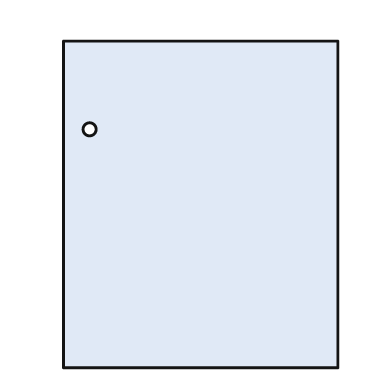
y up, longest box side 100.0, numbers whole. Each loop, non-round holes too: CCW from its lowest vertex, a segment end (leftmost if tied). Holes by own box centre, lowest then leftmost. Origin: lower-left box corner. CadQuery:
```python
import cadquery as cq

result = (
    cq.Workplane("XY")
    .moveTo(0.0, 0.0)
    .lineTo(84.0, 0.0)
    .lineTo(84.0, 100.0)
    .lineTo(0.0, 100.0)
    .close()
    .moveTo(8.0, 73.0)
    .circle(2.0)
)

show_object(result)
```